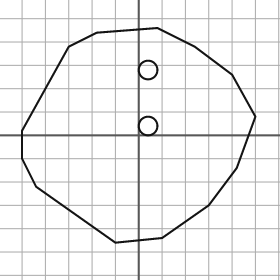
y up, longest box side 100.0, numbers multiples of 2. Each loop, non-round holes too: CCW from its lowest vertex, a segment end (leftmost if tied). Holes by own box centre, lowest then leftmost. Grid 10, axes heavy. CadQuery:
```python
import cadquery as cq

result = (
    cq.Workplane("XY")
    .moveTo(-10.0, -46.0)
    .lineTo(10.0, -44.0)
    .lineTo(30.0, -30.0)
    .lineTo(42.0, -14.0)
    .lineTo(50.0, 8.0)
    .lineTo(40.0, 26.0)
    .lineTo(24.0, 38.0)
    .lineTo(8.0, 46.0)
    .lineTo(-18.0, 44.0)
    .lineTo(-30.0, 38.0)
    .lineTo(-50.0, 2.0)
    .lineTo(-50.0, -10.0)
    .lineTo(-44.0, -22.0)
    .close()
    .moveTo(4.0, 4.0)
    .circle(4.0)
    .moveTo(4.0, 28.0)
    .circle(4.0)
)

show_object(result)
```